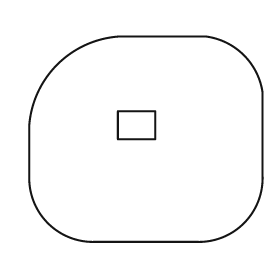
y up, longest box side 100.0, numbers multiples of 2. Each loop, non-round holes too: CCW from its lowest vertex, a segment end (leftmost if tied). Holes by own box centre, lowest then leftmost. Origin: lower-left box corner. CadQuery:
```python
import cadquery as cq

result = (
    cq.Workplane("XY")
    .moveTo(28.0, 0.0)
    .lineTo(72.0, 0.0)
    .threePointArc((92.0, 8.0), (100.0, 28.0))
    .lineTo(100.0, 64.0)
    .threePointArc((92.0, 80.0), (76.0, 88.0))
    .lineTo(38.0, 88.0)
    .threePointArc((12.0, 76.0), (0.0, 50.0))
    .lineTo(0.0, 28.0)
    .threePointArc((8.0, 8.0), (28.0, 0.0))
    .close()
    .moveTo(38.0, 44.0)
    .lineTo(54.0, 44.0)
    .lineTo(54.0, 56.0)
    .lineTo(38.0, 56.0)
    .close()
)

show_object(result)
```